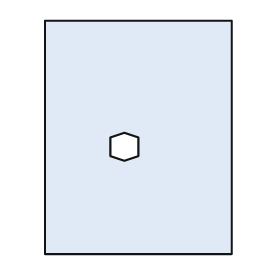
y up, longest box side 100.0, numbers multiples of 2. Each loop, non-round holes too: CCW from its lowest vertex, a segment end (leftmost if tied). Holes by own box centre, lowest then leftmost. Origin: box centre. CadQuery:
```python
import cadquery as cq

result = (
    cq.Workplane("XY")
    .moveTo(-40.0, -50.0)
    .lineTo(40.0, -50.0)
    .lineTo(40.0, 50.0)
    .lineTo(-40.0, 50.0)
    .close()
    .moveTo(-6.0, -10.0)
    .lineTo(0.0, -8.0)
    .lineTo(0.0, 0.0)
    .lineTo(-6.0, 2.0)
    .lineTo(-12.0, 0.0)
    .lineTo(-12.0, -8.0)
    .close()
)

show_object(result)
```